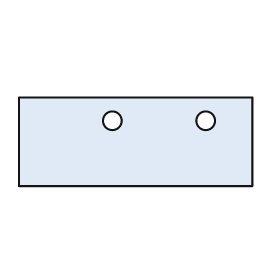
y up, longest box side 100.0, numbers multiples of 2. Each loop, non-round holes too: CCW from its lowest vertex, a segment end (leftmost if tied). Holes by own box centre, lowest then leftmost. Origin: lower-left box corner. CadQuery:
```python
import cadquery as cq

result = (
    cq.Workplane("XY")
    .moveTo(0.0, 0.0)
    .lineTo(100.0, 0.0)
    .lineTo(100.0, 38.0)
    .lineTo(0.0, 38.0)
    .close()
    .moveTo(40.0, 28.0)
    .circle(4.0)
    .moveTo(80.0, 28.0)
    .circle(4.0)
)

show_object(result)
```